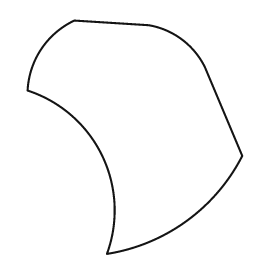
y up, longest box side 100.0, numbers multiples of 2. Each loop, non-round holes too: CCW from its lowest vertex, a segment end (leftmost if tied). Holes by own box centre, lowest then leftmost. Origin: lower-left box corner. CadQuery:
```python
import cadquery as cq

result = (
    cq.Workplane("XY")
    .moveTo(34.0, 0.0)
    .threePointArc((68.0, 14.0), (92.0, 42.0))
    .lineTo(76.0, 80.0)
    .threePointArc((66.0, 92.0), (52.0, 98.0))
    .lineTo(20.0, 100.0)
    .threePointArc((6.0, 88.0), (0.0, 70.0))
    .threePointArc((32.0, 42.0), (34.0, 0.0))
    .close()
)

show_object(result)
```